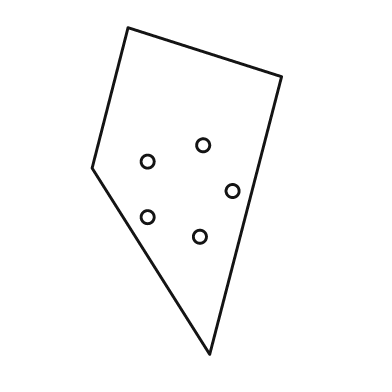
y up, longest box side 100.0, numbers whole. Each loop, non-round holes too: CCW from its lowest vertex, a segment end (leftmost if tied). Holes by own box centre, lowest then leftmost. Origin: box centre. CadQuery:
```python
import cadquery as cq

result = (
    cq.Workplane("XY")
    .moveTo(7.0, -50.0)
    .lineTo(29.0, 35.0)
    .lineTo(-18.0, 50.0)
    .lineTo(-29.0, 7.0)
    .close()
    .moveTo(4.0, -14.0)
    .circle(2.0)
    .moveTo(-12.0, -8.0)
    .circle(2.0)
    .moveTo(14.0, 0.0)
    .circle(2.0)
    .moveTo(-12.0, 9.0)
    .circle(2.0)
    .moveTo(5.0, 14.0)
    .circle(2.0)
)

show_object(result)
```